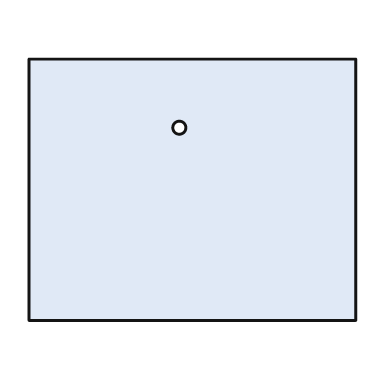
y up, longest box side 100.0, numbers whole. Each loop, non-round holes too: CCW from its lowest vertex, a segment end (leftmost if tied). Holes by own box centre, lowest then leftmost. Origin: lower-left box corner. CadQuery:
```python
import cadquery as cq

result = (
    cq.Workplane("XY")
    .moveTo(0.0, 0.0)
    .lineTo(100.0, 0.0)
    .lineTo(100.0, 80.0)
    .lineTo(0.0, 80.0)
    .close()
    .moveTo(46.0, 59.0)
    .circle(2.0)
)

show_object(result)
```